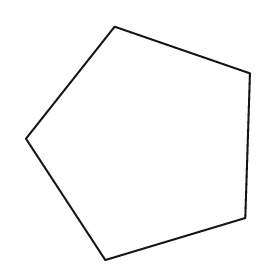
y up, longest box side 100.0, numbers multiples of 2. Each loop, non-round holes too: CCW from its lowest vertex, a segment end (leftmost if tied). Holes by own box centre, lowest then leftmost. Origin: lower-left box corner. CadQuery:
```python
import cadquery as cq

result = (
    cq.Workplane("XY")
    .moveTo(34.0, 0.0)
    .lineTo(94.0, 18.0)
    .lineTo(96.0, 80.0)
    .lineTo(38.0, 100.0)
    .lineTo(0.0, 52.0)
    .close()
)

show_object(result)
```